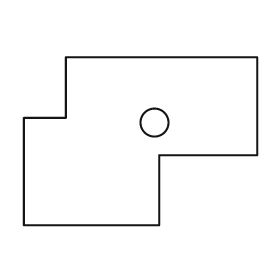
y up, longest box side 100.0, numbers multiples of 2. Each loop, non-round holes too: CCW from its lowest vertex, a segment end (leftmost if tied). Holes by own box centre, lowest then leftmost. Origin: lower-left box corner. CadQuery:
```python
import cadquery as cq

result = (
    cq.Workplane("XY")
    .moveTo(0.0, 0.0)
    .lineTo(58.0, 0.0)
    .lineTo(58.0, 30.0)
    .lineTo(100.0, 30.0)
    .lineTo(100.0, 72.0)
    .lineTo(18.0, 72.0)
    .lineTo(18.0, 46.0)
    .lineTo(0.0, 46.0)
    .close()
    .moveTo(56.0, 44.0)
    .circle(6.0)
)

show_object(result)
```